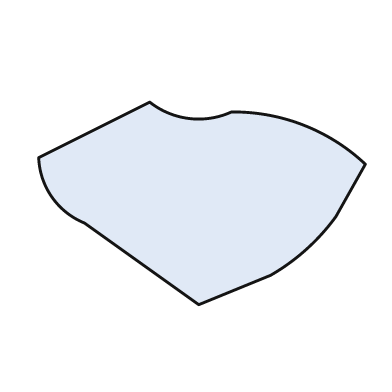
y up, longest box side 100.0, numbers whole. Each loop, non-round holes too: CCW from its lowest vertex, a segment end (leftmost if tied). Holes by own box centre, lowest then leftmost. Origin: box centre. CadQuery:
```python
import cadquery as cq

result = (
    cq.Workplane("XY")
    .moveTo(-1.0, -31.0)
    .lineTo(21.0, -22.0)
    .threePointArc((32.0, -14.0), (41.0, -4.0))
    .lineTo(50.0, 12.0)
    .threePointArc((31.0, 24.0), (9.0, 28.0))
    .threePointArc((-4.0, 26.0), (-16.0, 31.0))
    .lineTo(-50.0, 14.0)
    .threePointArc((-46.0, 2.0), (-36.0, -6.0))
    .close()
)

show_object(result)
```